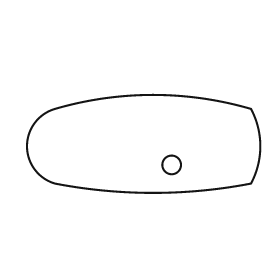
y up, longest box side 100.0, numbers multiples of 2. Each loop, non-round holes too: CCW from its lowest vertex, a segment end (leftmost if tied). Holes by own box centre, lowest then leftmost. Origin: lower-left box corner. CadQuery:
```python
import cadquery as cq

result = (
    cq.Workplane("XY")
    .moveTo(12.0, 4.0)
    .threePointArc((54.0, 0.0), (96.0, 4.0))
    .threePointArc((100.0, 20.0), (96.0, 36.0))
    .threePointArc((54.0, 42.0), (12.0, 36.0))
    .threePointArc((0.0, 20.0), (12.0, 4.0))
    .close()
    .moveTo(62.0, 12.0)
    .circle(4.0)
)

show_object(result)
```